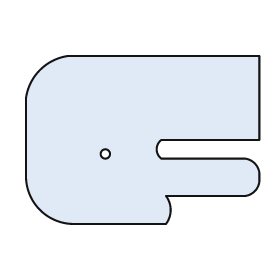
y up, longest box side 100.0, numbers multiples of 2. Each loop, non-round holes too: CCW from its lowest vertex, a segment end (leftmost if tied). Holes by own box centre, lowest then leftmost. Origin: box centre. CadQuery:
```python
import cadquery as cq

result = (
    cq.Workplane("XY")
    .moveTo(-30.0, -36.0)
    .lineTo(10.0, -36.0)
    .threePointArc((12.0, -30.0), (10.0, -24.0))
    .lineTo(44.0, -24.0)
    .threePointArc((48.0, -22.0), (50.0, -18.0))
    .lineTo(50.0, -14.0)
    .threePointArc((48.0, -10.0), (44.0, -8.0))
    .lineTo(8.0, -8.0)
    .threePointArc((6.0, -4.0), (8.0, 0.0))
    .lineTo(50.0, 0.0)
    .lineTo(50.0, 36.0)
    .lineTo(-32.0, 36.0)
    .threePointArc((-44.0, 30.0), (-50.0, 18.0))
    .lineTo(-50.0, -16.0)
    .threePointArc((-44.0, -30.0), (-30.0, -36.0))
    .close()
    .moveTo(-16.0, -6.0)
    .circle(2.0)
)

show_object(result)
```